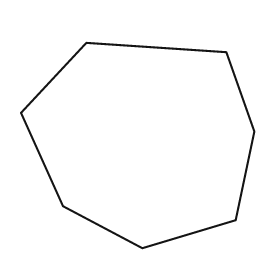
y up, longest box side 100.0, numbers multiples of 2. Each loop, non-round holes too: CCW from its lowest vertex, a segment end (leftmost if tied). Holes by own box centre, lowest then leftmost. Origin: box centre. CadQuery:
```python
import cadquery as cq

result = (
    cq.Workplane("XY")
    .moveTo(2.0, -44.0)
    .lineTo(42.0, -32.0)
    .lineTo(50.0, 6.0)
    .lineTo(38.0, 40.0)
    .lineTo(-22.0, 44.0)
    .lineTo(-50.0, 14.0)
    .lineTo(-32.0, -26.0)
    .close()
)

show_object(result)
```